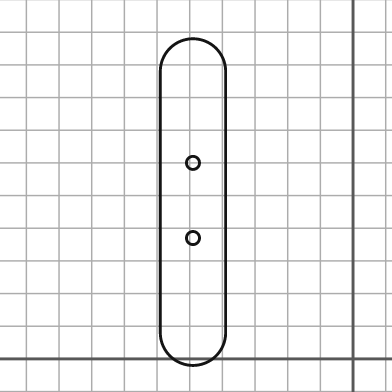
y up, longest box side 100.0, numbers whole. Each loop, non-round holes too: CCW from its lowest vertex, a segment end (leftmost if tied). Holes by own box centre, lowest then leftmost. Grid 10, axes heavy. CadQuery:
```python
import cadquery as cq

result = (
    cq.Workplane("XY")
    .moveTo(-59.0, 8.0)
    .threePointArc((-49.0, -2.0), (-39.0, 8.0))
    .lineTo(-39.0, 88.0)
    .threePointArc((-49.0, 98.0), (-59.0, 88.0))
    .close()
    .moveTo(-49.0, 37.0)
    .circle(2.0)
    .moveTo(-49.0, 60.0)
    .circle(2.0)
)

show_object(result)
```